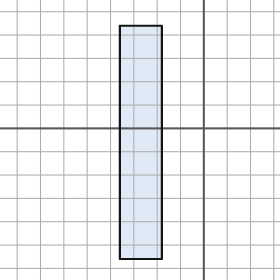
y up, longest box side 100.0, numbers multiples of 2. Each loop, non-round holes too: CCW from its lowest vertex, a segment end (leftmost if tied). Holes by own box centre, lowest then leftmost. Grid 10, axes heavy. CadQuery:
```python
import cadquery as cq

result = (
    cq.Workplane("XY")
    .moveTo(-36.0, -56.0)
    .lineTo(-18.0, -56.0)
    .lineTo(-18.0, 44.0)
    .lineTo(-36.0, 44.0)
    .close()
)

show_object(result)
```